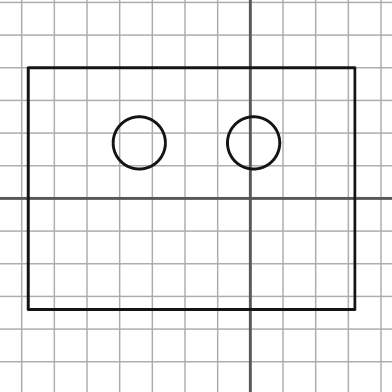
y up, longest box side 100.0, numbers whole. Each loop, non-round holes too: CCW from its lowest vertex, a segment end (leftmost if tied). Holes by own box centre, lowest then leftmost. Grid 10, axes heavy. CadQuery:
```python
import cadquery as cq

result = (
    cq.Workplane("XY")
    .moveTo(-68.0, -34.0)
    .lineTo(32.0, -34.0)
    .lineTo(32.0, 40.0)
    .lineTo(-68.0, 40.0)
    .close()
    .moveTo(-34.0, 17.0)
    .circle(8.0)
    .moveTo(1.0, 17.0)
    .circle(8.0)
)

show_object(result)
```